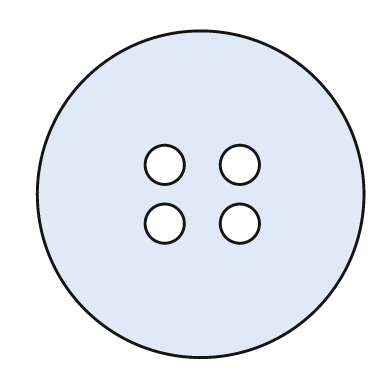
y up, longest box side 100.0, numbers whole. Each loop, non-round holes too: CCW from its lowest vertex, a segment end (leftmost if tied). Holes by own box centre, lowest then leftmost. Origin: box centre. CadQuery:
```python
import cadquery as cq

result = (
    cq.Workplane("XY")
    .moveTo(0.0, 0.0)
    .circle(50.0)
    .moveTo(-11.0, -9.0)
    .circle(6.0)
    .moveTo(12.0, -9.0)
    .circle(6.0)
    .moveTo(-11.0, 9.0)
    .circle(6.0)
    .moveTo(12.0, 9.0)
    .circle(6.0)
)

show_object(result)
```